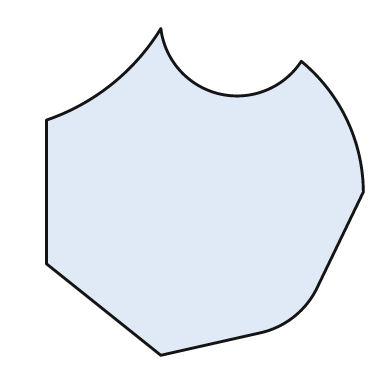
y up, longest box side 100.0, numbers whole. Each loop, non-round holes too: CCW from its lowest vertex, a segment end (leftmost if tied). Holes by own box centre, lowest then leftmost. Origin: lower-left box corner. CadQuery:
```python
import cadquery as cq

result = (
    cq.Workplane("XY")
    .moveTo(35.0, 0.0)
    .lineTo(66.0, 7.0)
    .threePointArc((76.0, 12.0), (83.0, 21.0))
    .lineTo(97.0, 50.0)
    .threePointArc((92.0, 72.0), (78.0, 90.0))
    .threePointArc((53.0, 80.0), (35.0, 100.0))
    .threePointArc((20.0, 83.0), (0.0, 72.0))
    .lineTo(0.0, 28.0)
    .close()
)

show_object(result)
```